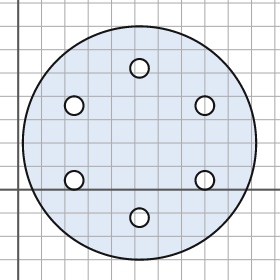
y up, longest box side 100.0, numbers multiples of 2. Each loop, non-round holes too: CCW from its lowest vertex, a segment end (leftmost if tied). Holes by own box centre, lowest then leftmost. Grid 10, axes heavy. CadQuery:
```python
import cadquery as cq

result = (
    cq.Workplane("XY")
    .moveTo(52.0, 20.0)
    .circle(50.0)
    .moveTo(52.0, -12.0)
    .circle(4.0)
    .moveTo(24.0, 4.0)
    .circle(4.0)
    .moveTo(80.0, 4.0)
    .circle(4.0)
    .moveTo(24.0, 36.0)
    .circle(4.0)
    .moveTo(80.0, 36.0)
    .circle(4.0)
    .moveTo(52.0, 52.0)
    .circle(4.0)
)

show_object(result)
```